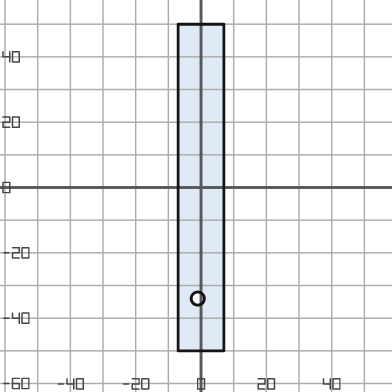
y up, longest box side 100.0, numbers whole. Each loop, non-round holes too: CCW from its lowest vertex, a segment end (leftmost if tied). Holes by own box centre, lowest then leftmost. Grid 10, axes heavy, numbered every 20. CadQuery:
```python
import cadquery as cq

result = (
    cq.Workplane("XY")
    .moveTo(-7.0, -50.0)
    .lineTo(7.0, -50.0)
    .lineTo(7.0, 50.0)
    .lineTo(-7.0, 50.0)
    .close()
    .moveTo(-1.0, -34.0)
    .circle(2.0)
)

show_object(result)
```